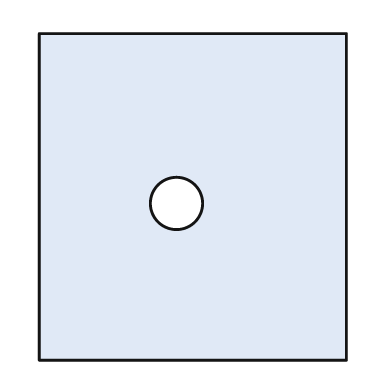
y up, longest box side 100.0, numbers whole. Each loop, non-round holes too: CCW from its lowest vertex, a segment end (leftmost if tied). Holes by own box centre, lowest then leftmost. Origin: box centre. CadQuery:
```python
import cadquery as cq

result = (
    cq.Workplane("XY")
    .moveTo(-47.0, -50.0)
    .lineTo(47.0, -50.0)
    .lineTo(47.0, 50.0)
    .lineTo(-47.0, 50.0)
    .close()
    .moveTo(-5.0, -2.0)
    .circle(8.0)
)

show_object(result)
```